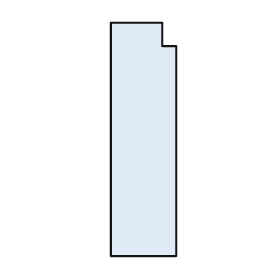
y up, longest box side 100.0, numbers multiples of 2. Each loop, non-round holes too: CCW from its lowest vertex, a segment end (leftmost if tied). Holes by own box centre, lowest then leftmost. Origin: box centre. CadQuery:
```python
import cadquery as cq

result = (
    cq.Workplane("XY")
    .moveTo(-14.0, -50.0)
    .lineTo(14.0, -50.0)
    .lineTo(14.0, 40.0)
    .lineTo(8.0, 40.0)
    .lineTo(8.0, 50.0)
    .lineTo(-14.0, 50.0)
    .close()
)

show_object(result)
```